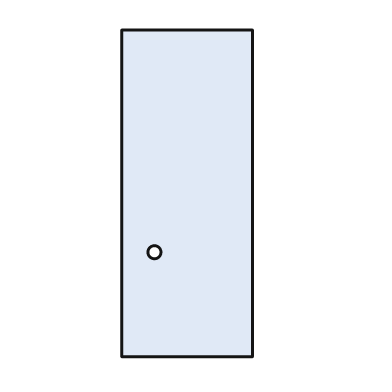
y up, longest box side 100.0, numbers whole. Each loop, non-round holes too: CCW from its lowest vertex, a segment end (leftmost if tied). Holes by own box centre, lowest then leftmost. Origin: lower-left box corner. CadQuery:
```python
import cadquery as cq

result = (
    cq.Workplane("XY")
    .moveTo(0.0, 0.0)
    .lineTo(40.0, 0.0)
    .lineTo(40.0, 100.0)
    .lineTo(0.0, 100.0)
    .close()
    .moveTo(10.0, 32.0)
    .circle(2.0)
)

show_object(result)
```